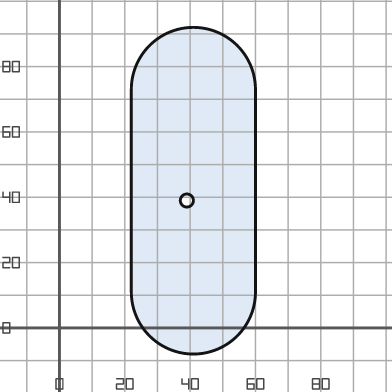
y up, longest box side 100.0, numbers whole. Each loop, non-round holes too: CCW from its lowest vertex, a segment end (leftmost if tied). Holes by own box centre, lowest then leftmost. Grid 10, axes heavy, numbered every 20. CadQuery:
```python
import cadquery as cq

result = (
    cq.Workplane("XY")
    .moveTo(22.0, 11.0)
    .threePointArc((41.0, -8.0), (60.0, 11.0))
    .lineTo(60.0, 73.0)
    .threePointArc((41.0, 92.0), (22.0, 73.0))
    .close()
    .moveTo(39.0, 39.0)
    .circle(2.0)
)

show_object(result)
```